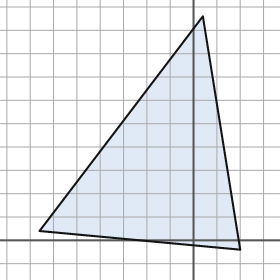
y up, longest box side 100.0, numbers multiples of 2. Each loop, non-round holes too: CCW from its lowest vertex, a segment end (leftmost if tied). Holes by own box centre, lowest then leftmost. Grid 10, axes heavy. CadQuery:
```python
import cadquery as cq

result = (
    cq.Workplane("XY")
    .moveTo(20.0, -4.0)
    .lineTo(4.0, 96.0)
    .lineTo(-66.0, 4.0)
    .close()
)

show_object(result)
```